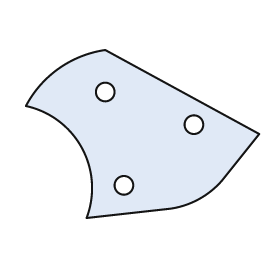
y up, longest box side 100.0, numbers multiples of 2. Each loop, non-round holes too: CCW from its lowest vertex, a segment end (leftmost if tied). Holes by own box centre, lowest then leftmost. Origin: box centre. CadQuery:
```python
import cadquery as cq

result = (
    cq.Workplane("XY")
    .moveTo(-24.0, -36.0)
    .lineTo(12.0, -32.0)
    .threePointArc((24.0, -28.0), (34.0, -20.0))
    .lineTo(50.0, 0.0)
    .lineTo(-16.0, 36.0)
    .threePointArc((-36.0, 28.0), (-50.0, 12.0))
    .threePointArc((-26.0, -6.0), (-24.0, -36.0))
    .close()
    .moveTo(-8.0, -22.0)
    .circle(4.0)
    .moveTo(22.0, 4.0)
    .circle(4.0)
    .moveTo(-16.0, 18.0)
    .circle(4.0)
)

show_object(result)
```